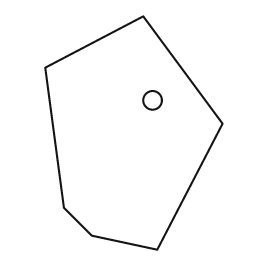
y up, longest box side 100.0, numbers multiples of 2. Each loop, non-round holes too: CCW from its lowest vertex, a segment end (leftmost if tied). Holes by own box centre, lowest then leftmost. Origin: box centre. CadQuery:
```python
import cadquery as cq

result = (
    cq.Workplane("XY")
    .moveTo(10.0, -50.0)
    .lineTo(38.0, 4.0)
    .lineTo(4.0, 50.0)
    .lineTo(-38.0, 28.0)
    .lineTo(-30.0, -32.0)
    .lineTo(-18.0, -44.0)
    .close()
    .moveTo(8.0, 14.0)
    .circle(4.0)
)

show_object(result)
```